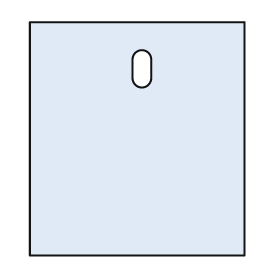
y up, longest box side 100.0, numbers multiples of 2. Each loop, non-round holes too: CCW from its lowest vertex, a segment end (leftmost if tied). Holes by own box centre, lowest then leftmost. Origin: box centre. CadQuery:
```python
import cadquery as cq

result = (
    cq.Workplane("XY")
    .moveTo(-46.0, -50.0)
    .lineTo(46.0, -50.0)
    .lineTo(46.0, 50.0)
    .lineTo(-46.0, 50.0)
    .close()
    .moveTo(-2.0, 26.0)
    .threePointArc((2.0, 22.0), (6.0, 26.0))
    .lineTo(6.0, 34.0)
    .threePointArc((2.0, 38.0), (-2.0, 34.0))
    .close()
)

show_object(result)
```